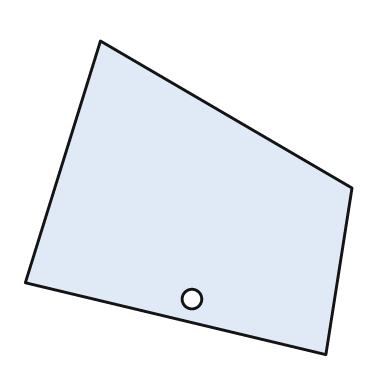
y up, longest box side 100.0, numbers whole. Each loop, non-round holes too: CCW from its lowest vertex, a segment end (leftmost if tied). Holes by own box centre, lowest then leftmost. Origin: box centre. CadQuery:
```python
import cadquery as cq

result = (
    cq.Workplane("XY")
    .moveTo(42.0, -48.0)
    .lineTo(50.0, 3.0)
    .lineTo(-27.0, 48.0)
    .lineTo(-50.0, -26.0)
    .close()
    .moveTo(1.0, -31.0)
    .circle(3.0)
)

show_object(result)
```